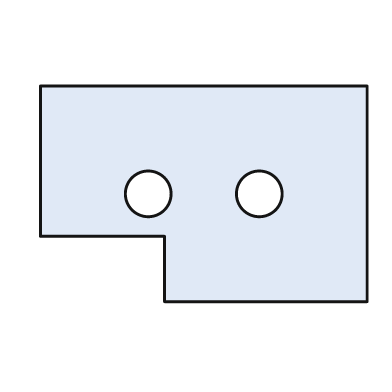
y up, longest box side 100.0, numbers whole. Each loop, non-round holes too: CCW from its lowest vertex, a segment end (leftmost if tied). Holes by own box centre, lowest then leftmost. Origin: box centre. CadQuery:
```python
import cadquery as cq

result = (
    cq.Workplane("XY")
    .moveTo(-12.0, -33.0)
    .lineTo(50.0, -33.0)
    .lineTo(50.0, 33.0)
    .lineTo(-50.0, 33.0)
    .lineTo(-50.0, -13.0)
    .lineTo(-12.0, -13.0)
    .close()
    .moveTo(-17.0, 0.0)
    .circle(7.0)
    .moveTo(17.0, 0.0)
    .circle(7.0)
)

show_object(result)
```